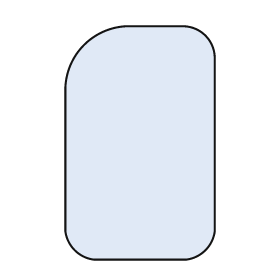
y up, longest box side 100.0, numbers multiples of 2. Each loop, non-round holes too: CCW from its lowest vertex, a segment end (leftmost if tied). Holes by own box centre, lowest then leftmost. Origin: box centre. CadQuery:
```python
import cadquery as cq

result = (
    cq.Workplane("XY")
    .moveTo(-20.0, -50.0)
    .lineTo(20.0, -50.0)
    .threePointArc((28.0, -46.0), (32.0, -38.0))
    .lineTo(32.0, 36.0)
    .threePointArc((28.0, 46.0), (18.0, 50.0))
    .lineTo(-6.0, 50.0)
    .threePointArc((-24.0, 42.0), (-32.0, 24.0))
    .lineTo(-32.0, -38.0)
    .threePointArc((-28.0, -46.0), (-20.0, -50.0))
    .close()
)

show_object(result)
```